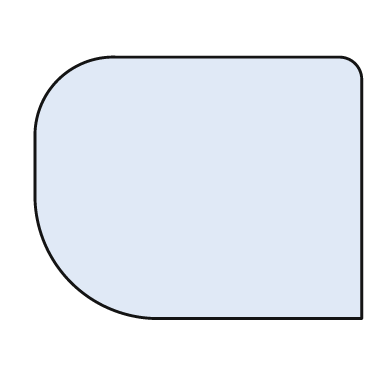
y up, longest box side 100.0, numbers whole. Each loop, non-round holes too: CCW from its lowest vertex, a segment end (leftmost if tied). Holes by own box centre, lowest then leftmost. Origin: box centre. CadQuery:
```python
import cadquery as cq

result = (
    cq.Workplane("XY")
    .moveTo(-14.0, -40.0)
    .lineTo(50.0, -40.0)
    .lineTo(50.0, 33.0)
    .threePointArc((48.0, 38.0), (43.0, 40.0))
    .lineTo(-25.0, 40.0)
    .threePointArc((-43.0, 33.0), (-50.0, 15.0))
    .lineTo(-50.0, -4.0)
    .threePointArc((-39.0, -29.0), (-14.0, -40.0))
    .close()
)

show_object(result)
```